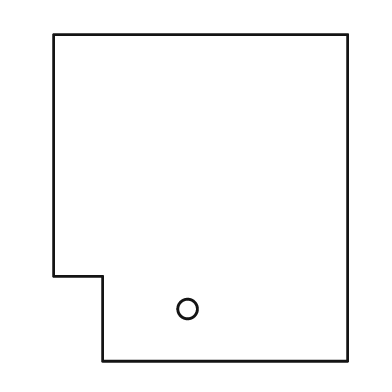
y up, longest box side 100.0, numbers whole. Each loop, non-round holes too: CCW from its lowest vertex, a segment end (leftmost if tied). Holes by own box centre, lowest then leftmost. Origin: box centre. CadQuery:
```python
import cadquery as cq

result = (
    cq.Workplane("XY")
    .moveTo(-30.0, -50.0)
    .lineTo(45.0, -50.0)
    .lineTo(45.0, 50.0)
    .lineTo(-45.0, 50.0)
    .lineTo(-45.0, -24.0)
    .lineTo(-30.0, -24.0)
    .close()
    .moveTo(-4.0, -34.0)
    .circle(3.0)
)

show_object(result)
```